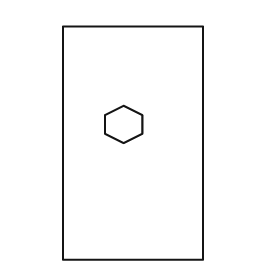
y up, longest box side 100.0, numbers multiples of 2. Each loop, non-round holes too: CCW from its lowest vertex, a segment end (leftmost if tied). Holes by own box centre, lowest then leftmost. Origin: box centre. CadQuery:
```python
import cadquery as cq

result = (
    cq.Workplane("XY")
    .moveTo(-30.0, -50.0)
    .lineTo(30.0, -50.0)
    .lineTo(30.0, 50.0)
    .lineTo(-30.0, 50.0)
    .close()
    .moveTo(-4.0, 0.0)
    .lineTo(4.0, 4.0)
    .lineTo(4.0, 12.0)
    .lineTo(-4.0, 16.0)
    .lineTo(-12.0, 12.0)
    .lineTo(-12.0, 4.0)
    .close()
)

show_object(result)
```